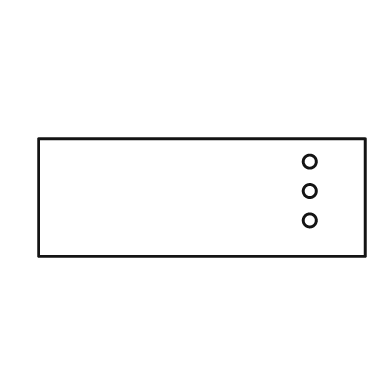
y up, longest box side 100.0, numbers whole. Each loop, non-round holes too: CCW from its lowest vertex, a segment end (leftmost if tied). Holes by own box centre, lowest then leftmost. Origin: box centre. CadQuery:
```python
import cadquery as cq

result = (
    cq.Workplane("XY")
    .moveTo(-50.0, -18.0)
    .lineTo(50.0, -18.0)
    .lineTo(50.0, 18.0)
    .lineTo(-50.0, 18.0)
    .close()
    .moveTo(33.0, -7.0)
    .circle(2.0)
    .moveTo(33.0, 2.0)
    .circle(2.0)
    .moveTo(33.0, 11.0)
    .circle(2.0)
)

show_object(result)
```